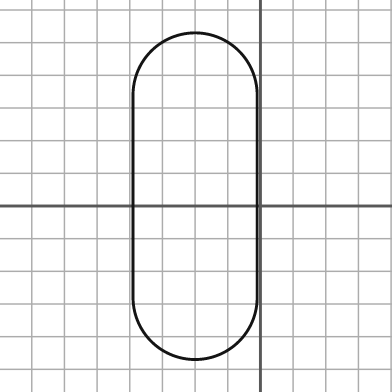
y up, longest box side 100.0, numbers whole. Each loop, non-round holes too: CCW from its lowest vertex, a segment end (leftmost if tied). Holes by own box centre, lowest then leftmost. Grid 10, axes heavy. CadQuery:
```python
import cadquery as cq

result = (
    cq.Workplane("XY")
    .moveTo(-39.0, -28.0)
    .threePointArc((-20.0, -47.0), (-1.0, -28.0))
    .lineTo(-1.0, 34.0)
    .threePointArc((-20.0, 53.0), (-39.0, 34.0))
    .close()
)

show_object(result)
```